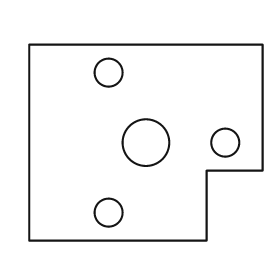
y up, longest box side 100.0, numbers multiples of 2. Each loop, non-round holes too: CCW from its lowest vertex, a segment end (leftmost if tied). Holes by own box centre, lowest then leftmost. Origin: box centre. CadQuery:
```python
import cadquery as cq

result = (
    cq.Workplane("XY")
    .moveTo(-50.0, -42.0)
    .lineTo(26.0, -42.0)
    .lineTo(26.0, -12.0)
    .lineTo(50.0, -12.0)
    .lineTo(50.0, 42.0)
    .lineTo(-50.0, 42.0)
    .close()
    .moveTo(-16.0, -30.0)
    .circle(6.0)
    .moveTo(0.0, 0.0)
    .circle(10.0)
    .moveTo(34.0, 0.0)
    .circle(6.0)
    .moveTo(-16.0, 30.0)
    .circle(6.0)
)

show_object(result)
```